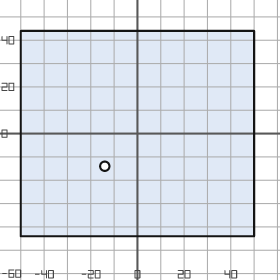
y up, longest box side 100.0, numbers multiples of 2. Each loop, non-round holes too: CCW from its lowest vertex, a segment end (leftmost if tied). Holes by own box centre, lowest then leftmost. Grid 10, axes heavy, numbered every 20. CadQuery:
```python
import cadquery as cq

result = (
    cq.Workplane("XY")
    .moveTo(-50.0, -44.0)
    .lineTo(50.0, -44.0)
    .lineTo(50.0, 44.0)
    .lineTo(-50.0, 44.0)
    .close()
    .moveTo(-14.0, -14.0)
    .circle(2.0)
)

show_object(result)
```